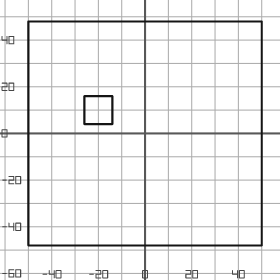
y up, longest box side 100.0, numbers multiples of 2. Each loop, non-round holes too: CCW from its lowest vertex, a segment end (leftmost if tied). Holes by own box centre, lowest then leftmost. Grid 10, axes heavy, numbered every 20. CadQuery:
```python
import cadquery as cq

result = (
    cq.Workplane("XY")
    .moveTo(-50.0, -48.0)
    .lineTo(50.0, -48.0)
    .lineTo(50.0, 48.0)
    .lineTo(-50.0, 48.0)
    .close()
    .moveTo(-26.0, 4.0)
    .lineTo(-14.0, 4.0)
    .lineTo(-14.0, 16.0)
    .lineTo(-26.0, 16.0)
    .close()
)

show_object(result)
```